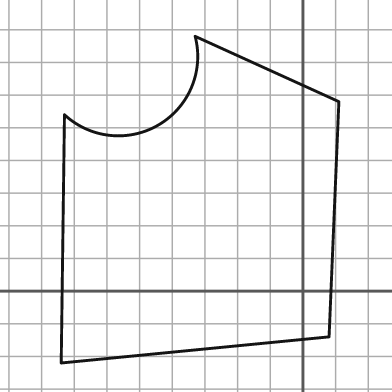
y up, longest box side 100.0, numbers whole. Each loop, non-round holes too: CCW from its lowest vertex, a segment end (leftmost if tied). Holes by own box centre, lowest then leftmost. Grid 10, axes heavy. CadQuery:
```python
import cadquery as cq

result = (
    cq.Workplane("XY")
    .moveTo(-74.0, -22.0)
    .lineTo(8.0, -14.0)
    .lineTo(11.0, 58.0)
    .lineTo(-33.0, 78.0)
    .threePointArc((-44.0, 51.0), (-73.0, 54.0))
    .close()
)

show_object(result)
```